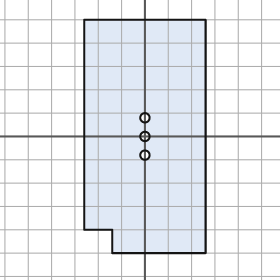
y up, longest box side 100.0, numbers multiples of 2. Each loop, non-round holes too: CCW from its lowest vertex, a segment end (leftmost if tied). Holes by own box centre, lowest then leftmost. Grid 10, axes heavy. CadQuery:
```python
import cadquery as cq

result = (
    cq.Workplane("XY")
    .moveTo(-14.0, -50.0)
    .lineTo(26.0, -50.0)
    .lineTo(26.0, 50.0)
    .lineTo(-26.0, 50.0)
    .lineTo(-26.0, -40.0)
    .lineTo(-14.0, -40.0)
    .close()
    .moveTo(0.0, -8.0)
    .circle(2.0)
    .moveTo(0.0, 0.0)
    .circle(2.0)
    .moveTo(0.0, 8.0)
    .circle(2.0)
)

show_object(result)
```